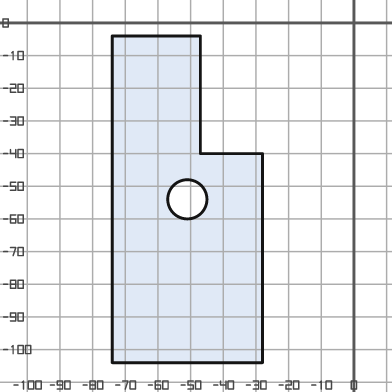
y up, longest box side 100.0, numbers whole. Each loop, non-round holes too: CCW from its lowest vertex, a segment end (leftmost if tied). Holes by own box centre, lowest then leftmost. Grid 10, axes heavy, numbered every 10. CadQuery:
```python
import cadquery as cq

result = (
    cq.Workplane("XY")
    .moveTo(-74.0, -104.0)
    .lineTo(-28.0, -104.0)
    .lineTo(-28.0, -40.0)
    .lineTo(-47.0, -40.0)
    .lineTo(-47.0, -4.0)
    .lineTo(-74.0, -4.0)
    .close()
    .moveTo(-51.0, -54.0)
    .circle(6.0)
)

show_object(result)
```